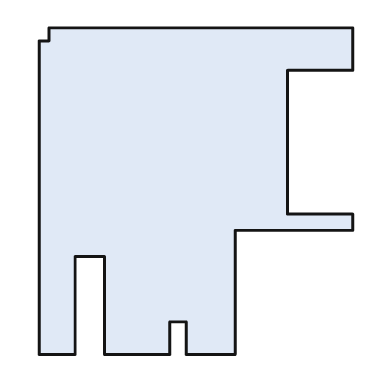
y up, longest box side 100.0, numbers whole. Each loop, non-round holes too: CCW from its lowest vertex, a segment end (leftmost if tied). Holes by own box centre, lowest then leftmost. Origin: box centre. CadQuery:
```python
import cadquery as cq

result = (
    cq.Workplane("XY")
    .moveTo(-48.0, -50.0)
    .lineTo(-37.0, -50.0)
    .lineTo(-37.0, -20.0)
    .lineTo(-28.0, -20.0)
    .lineTo(-28.0, -50.0)
    .lineTo(-8.0, -50.0)
    .lineTo(-8.0, -40.0)
    .lineTo(-3.0, -40.0)
    .lineTo(-3.0, -50.0)
    .lineTo(12.0, -50.0)
    .lineTo(12.0, -12.0)
    .lineTo(48.0, -12.0)
    .lineTo(48.0, -7.0)
    .lineTo(28.0, -7.0)
    .lineTo(28.0, 37.0)
    .lineTo(48.0, 37.0)
    .lineTo(48.0, 50.0)
    .lineTo(-45.0, 50.0)
    .lineTo(-45.0, 46.0)
    .lineTo(-48.0, 46.0)
    .close()
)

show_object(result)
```